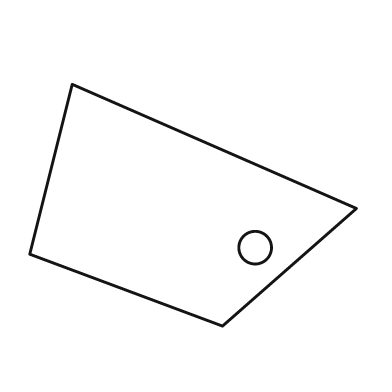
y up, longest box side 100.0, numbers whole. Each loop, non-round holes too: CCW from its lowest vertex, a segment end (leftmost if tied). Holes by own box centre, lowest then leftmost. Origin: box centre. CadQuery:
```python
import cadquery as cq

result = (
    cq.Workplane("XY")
    .moveTo(9.0, -37.0)
    .lineTo(50.0, -1.0)
    .lineTo(-37.0, 37.0)
    .lineTo(-50.0, -15.0)
    .close()
    .moveTo(19.0, -13.0)
    .circle(5.0)
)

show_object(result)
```